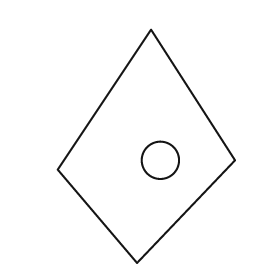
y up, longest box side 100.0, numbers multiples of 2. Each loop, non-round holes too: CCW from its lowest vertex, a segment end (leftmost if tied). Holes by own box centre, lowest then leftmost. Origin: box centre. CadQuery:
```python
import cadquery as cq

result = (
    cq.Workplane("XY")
    .moveTo(-4.0, -50.0)
    .lineTo(38.0, -6.0)
    .lineTo(2.0, 50.0)
    .lineTo(-38.0, -10.0)
    .close()
    .moveTo(6.0, -6.0)
    .circle(8.0)
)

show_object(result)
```